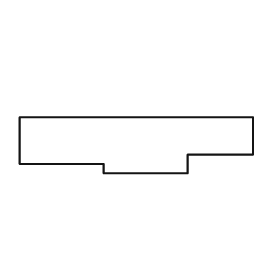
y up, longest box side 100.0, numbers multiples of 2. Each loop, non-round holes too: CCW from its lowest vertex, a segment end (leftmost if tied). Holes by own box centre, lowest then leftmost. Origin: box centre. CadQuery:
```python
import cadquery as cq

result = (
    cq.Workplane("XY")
    .moveTo(-14.0, -12.0)
    .lineTo(22.0, -12.0)
    .lineTo(22.0, -4.0)
    .lineTo(50.0, -4.0)
    .lineTo(50.0, 12.0)
    .lineTo(-50.0, 12.0)
    .lineTo(-50.0, -8.0)
    .lineTo(-14.0, -8.0)
    .close()
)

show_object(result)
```